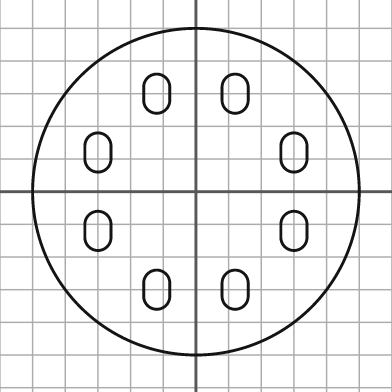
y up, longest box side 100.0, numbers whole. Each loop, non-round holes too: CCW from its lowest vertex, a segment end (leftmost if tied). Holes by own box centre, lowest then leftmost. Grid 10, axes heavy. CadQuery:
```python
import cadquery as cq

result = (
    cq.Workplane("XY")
    .moveTo(0.0, 0.0)
    .circle(50.0)
    .moveTo(-16.0, -32.0)
    .threePointArc((-12.0, -36.0), (-8.0, -32.0))
    .lineTo(-8.0, -28.0)
    .threePointArc((-12.0, -24.0), (-16.0, -28.0))
    .close()
    .moveTo(8.0, -32.0)
    .threePointArc((12.0, -36.0), (16.0, -32.0))
    .lineTo(16.0, -28.0)
    .threePointArc((12.0, -24.0), (8.0, -28.0))
    .close()
    .moveTo(-34.0, -14.0)
    .threePointArc((-30.0, -18.0), (-26.0, -14.0))
    .lineTo(-26.0, -10.0)
    .threePointArc((-30.0, -6.0), (-34.0, -10.0))
    .close()
    .moveTo(26.0, -14.0)
    .threePointArc((30.0, -18.0), (34.0, -14.0))
    .lineTo(34.0, -10.0)
    .threePointArc((30.0, -6.0), (26.0, -10.0))
    .close()
    .moveTo(-34.0, 10.0)
    .threePointArc((-30.0, 6.0), (-26.0, 10.0))
    .lineTo(-26.0, 14.0)
    .threePointArc((-30.0, 18.0), (-34.0, 14.0))
    .close()
    .moveTo(26.0, 10.0)
    .threePointArc((30.0, 6.0), (34.0, 10.0))
    .lineTo(34.0, 14.0)
    .threePointArc((30.0, 18.0), (26.0, 14.0))
    .close()
    .moveTo(-16.0, 28.0)
    .threePointArc((-12.0, 24.0), (-8.0, 28.0))
    .lineTo(-8.0, 32.0)
    .threePointArc((-12.0, 36.0), (-16.0, 32.0))
    .close()
    .moveTo(8.0, 28.0)
    .threePointArc((12.0, 24.0), (16.0, 28.0))
    .lineTo(16.0, 32.0)
    .threePointArc((12.0, 36.0), (8.0, 32.0))
    .close()
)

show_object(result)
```